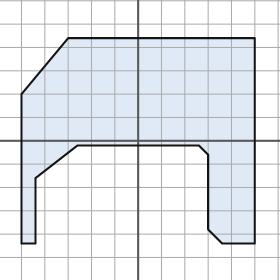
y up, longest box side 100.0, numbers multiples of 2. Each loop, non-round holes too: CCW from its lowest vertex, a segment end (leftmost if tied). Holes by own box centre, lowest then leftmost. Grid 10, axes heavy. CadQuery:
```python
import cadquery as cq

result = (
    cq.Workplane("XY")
    .moveTo(-50.0, -44.0)
    .lineTo(-44.0, -44.0)
    .lineTo(-44.0, -16.0)
    .lineTo(-26.0, -2.0)
    .lineTo(26.0, -2.0)
    .lineTo(30.0, -6.0)
    .lineTo(30.0, -38.0)
    .lineTo(36.0, -44.0)
    .lineTo(50.0, -44.0)
    .lineTo(50.0, 44.0)
    .lineTo(-30.0, 44.0)
    .lineTo(-50.0, 20.0)
    .close()
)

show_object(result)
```